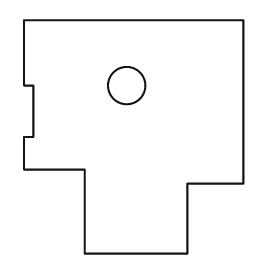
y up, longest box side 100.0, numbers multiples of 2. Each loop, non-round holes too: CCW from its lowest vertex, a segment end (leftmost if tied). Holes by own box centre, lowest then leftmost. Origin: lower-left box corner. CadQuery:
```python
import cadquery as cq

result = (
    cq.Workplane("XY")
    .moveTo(26.0, 0.0)
    .lineTo(70.0, 0.0)
    .lineTo(70.0, 30.0)
    .lineTo(94.0, 30.0)
    .lineTo(94.0, 100.0)
    .lineTo(0.0, 100.0)
    .lineTo(0.0, 72.0)
    .lineTo(4.0, 72.0)
    .lineTo(4.0, 50.0)
    .lineTo(0.0, 50.0)
    .lineTo(0.0, 36.0)
    .lineTo(26.0, 36.0)
    .close()
    .moveTo(44.0, 72.0)
    .circle(8.0)
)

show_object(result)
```